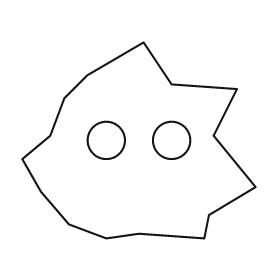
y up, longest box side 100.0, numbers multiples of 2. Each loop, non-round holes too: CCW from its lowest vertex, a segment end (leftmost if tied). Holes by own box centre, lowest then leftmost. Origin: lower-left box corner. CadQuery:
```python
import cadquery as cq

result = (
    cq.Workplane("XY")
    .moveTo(36.0, 0.0)
    .lineTo(50.0, 2.0)
    .lineTo(78.0, 0.0)
    .lineTo(80.0, 10.0)
    .lineTo(100.0, 22.0)
    .lineTo(82.0, 44.0)
    .lineTo(92.0, 64.0)
    .lineTo(64.0, 66.0)
    .lineTo(52.0, 84.0)
    .lineTo(28.0, 70.0)
    .lineTo(18.0, 60.0)
    .lineTo(12.0, 44.0)
    .lineTo(0.0, 34.0)
    .lineTo(8.0, 20.0)
    .lineTo(20.0, 6.0)
    .close()
    .moveTo(36.0, 42.0)
    .circle(8.0)
    .moveTo(64.0, 42.0)
    .circle(8.0)
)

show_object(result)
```